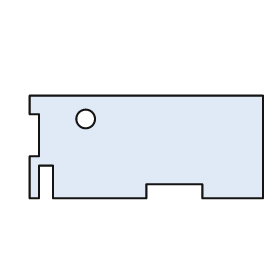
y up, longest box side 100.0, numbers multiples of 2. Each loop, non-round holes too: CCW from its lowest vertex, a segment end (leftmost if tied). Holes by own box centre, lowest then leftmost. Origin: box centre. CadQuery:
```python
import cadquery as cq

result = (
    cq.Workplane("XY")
    .moveTo(-50.0, -22.0)
    .lineTo(-46.0, -22.0)
    .lineTo(-46.0, -8.0)
    .lineTo(-40.0, -8.0)
    .lineTo(-40.0, -22.0)
    .lineTo(0.0, -22.0)
    .lineTo(0.0, -16.0)
    .lineTo(24.0, -16.0)
    .lineTo(24.0, -22.0)
    .lineTo(50.0, -22.0)
    .lineTo(50.0, 22.0)
    .lineTo(-50.0, 22.0)
    .lineTo(-50.0, 14.0)
    .lineTo(-46.0, 14.0)
    .lineTo(-46.0, -4.0)
    .lineTo(-50.0, -4.0)
    .close()
    .moveTo(-26.0, 12.0)
    .circle(4.0)
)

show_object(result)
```